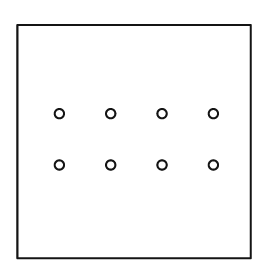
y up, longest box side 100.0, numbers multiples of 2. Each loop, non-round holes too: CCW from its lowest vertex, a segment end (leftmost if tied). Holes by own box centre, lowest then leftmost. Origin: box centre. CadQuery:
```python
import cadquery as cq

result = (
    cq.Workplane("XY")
    .moveTo(-50.0, -50.0)
    .lineTo(50.0, -50.0)
    .lineTo(50.0, 50.0)
    .lineTo(-50.0, 50.0)
    .close()
    .moveTo(-32.0, -10.0)
    .circle(2.0)
    .moveTo(-10.0, -10.0)
    .circle(2.0)
    .moveTo(12.0, -10.0)
    .circle(2.0)
    .moveTo(34.0, -10.0)
    .circle(2.0)
    .moveTo(-32.0, 12.0)
    .circle(2.0)
    .moveTo(-10.0, 12.0)
    .circle(2.0)
    .moveTo(12.0, 12.0)
    .circle(2.0)
    .moveTo(34.0, 12.0)
    .circle(2.0)
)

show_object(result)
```